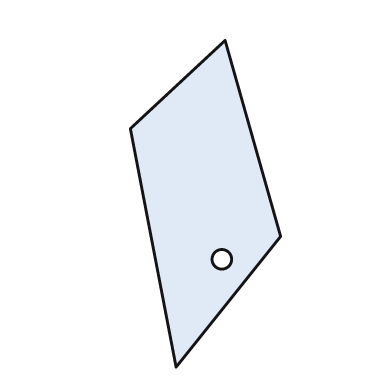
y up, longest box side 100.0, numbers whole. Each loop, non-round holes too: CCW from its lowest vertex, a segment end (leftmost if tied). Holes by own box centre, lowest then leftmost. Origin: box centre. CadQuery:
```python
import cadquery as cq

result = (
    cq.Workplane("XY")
    .moveTo(-9.0, -50.0)
    .lineTo(23.0, -10.0)
    .lineTo(6.0, 50.0)
    .lineTo(-23.0, 23.0)
    .close()
    .moveTo(5.0, -17.0)
    .circle(3.0)
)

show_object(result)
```